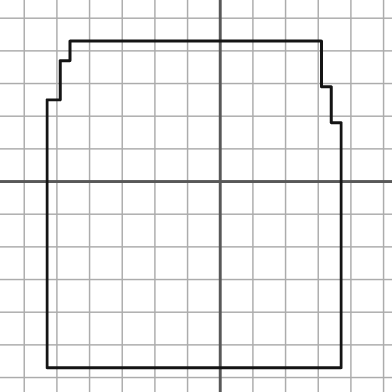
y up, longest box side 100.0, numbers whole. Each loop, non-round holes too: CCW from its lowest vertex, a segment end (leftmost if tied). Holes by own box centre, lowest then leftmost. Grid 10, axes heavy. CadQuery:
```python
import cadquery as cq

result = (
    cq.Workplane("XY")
    .moveTo(-53.0, -57.0)
    .lineTo(37.0, -57.0)
    .lineTo(37.0, 18.0)
    .lineTo(34.0, 18.0)
    .lineTo(34.0, 29.0)
    .lineTo(31.0, 29.0)
    .lineTo(31.0, 43.0)
    .lineTo(-46.0, 43.0)
    .lineTo(-46.0, 37.0)
    .lineTo(-49.0, 37.0)
    .lineTo(-49.0, 25.0)
    .lineTo(-53.0, 25.0)
    .close()
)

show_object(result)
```